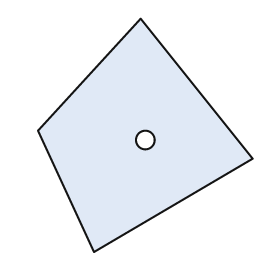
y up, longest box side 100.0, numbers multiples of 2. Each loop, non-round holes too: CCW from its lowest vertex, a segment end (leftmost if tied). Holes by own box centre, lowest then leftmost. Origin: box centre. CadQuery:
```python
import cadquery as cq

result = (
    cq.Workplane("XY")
    .moveTo(-22.0, -50.0)
    .lineTo(46.0, -10.0)
    .lineTo(-2.0, 50.0)
    .lineTo(-46.0, 2.0)
    .close()
    .moveTo(0.0, -2.0)
    .circle(4.0)
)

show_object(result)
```